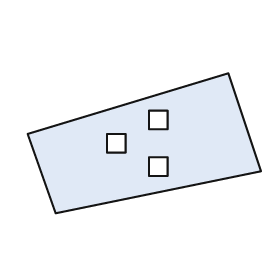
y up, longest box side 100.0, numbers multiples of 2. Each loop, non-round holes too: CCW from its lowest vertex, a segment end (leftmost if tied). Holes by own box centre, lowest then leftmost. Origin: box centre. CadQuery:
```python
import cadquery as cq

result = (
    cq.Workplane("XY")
    .moveTo(-38.0, -30.0)
    .lineTo(50.0, -12.0)
    .lineTo(36.0, 30.0)
    .lineTo(-50.0, 4.0)
    .close()
    .moveTo(2.0, -14.0)
    .lineTo(10.0, -14.0)
    .lineTo(10.0, -6.0)
    .lineTo(2.0, -6.0)
    .close()
    .moveTo(-16.0, -4.0)
    .lineTo(-8.0, -4.0)
    .lineTo(-8.0, 4.0)
    .lineTo(-16.0, 4.0)
    .close()
    .moveTo(2.0, 6.0)
    .lineTo(10.0, 6.0)
    .lineTo(10.0, 14.0)
    .lineTo(2.0, 14.0)
    .close()
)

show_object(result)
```